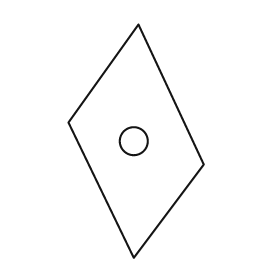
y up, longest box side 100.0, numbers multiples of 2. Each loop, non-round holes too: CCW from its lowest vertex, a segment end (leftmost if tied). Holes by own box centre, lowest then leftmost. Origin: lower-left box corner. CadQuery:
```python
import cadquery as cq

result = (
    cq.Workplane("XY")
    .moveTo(28.0, 0.0)
    .lineTo(58.0, 40.0)
    .lineTo(30.0, 100.0)
    .lineTo(0.0, 58.0)
    .close()
    .moveTo(28.0, 50.0)
    .circle(6.0)
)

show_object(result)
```